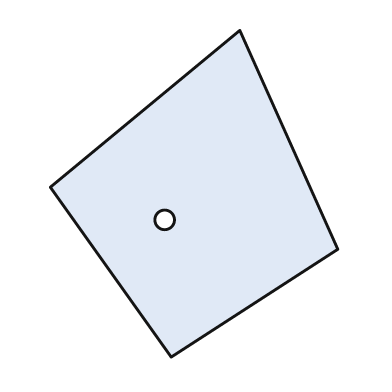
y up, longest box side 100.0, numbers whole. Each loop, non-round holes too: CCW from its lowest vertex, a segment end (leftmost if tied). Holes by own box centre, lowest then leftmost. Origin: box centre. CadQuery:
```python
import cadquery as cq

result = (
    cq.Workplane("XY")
    .moveTo(-7.0, -50.0)
    .lineTo(44.0, -17.0)
    .lineTo(14.0, 50.0)
    .lineTo(-44.0, 2.0)
    .close()
    .moveTo(-9.0, -8.0)
    .circle(3.0)
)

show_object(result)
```